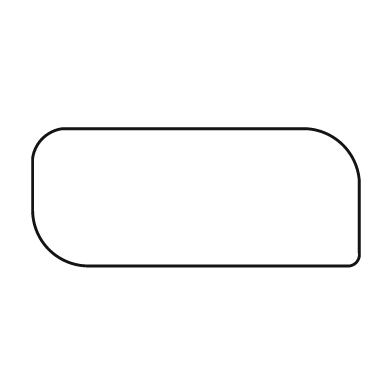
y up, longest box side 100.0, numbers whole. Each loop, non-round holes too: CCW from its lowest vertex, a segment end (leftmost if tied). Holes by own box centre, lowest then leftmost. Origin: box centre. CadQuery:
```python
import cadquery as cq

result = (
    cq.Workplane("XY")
    .moveTo(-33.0, -21.0)
    .lineTo(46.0, -21.0)
    .threePointArc((49.0, -20.0), (50.0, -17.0))
    .lineTo(50.0, 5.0)
    .threePointArc((45.0, 16.0), (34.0, 21.0))
    .lineTo(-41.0, 21.0)
    .threePointArc((-47.0, 18.0), (-50.0, 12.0))
    .lineTo(-50.0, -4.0)
    .threePointArc((-45.0, -16.0), (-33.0, -21.0))
    .close()
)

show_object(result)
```